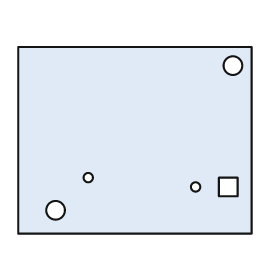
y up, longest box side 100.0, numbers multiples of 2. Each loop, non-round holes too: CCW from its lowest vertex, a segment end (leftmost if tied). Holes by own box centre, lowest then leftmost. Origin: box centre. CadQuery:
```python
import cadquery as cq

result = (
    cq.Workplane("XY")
    .moveTo(-50.0, -40.0)
    .lineTo(50.0, -40.0)
    .lineTo(50.0, 40.0)
    .lineTo(-50.0, 40.0)
    .close()
    .moveTo(-34.0, -30.0)
    .circle(4.0)
    .moveTo(26.0, -20.0)
    .circle(2.0)
    .moveTo(36.0, -24.0)
    .lineTo(44.0, -24.0)
    .lineTo(44.0, -16.0)
    .lineTo(36.0, -16.0)
    .close()
    .moveTo(-20.0, -16.0)
    .circle(2.0)
    .moveTo(42.0, 32.0)
    .circle(4.0)
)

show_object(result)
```